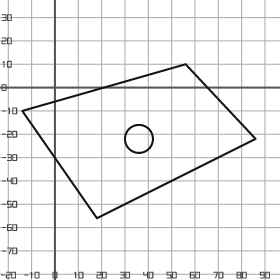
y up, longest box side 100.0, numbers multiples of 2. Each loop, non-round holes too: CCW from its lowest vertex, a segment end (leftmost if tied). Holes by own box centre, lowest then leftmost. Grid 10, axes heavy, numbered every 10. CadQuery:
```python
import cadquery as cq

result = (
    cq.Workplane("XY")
    .moveTo(18.0, -56.0)
    .lineTo(86.0, -22.0)
    .lineTo(56.0, 10.0)
    .lineTo(-14.0, -10.0)
    .close()
    .moveTo(36.0, -22.0)
    .circle(6.0)
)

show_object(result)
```